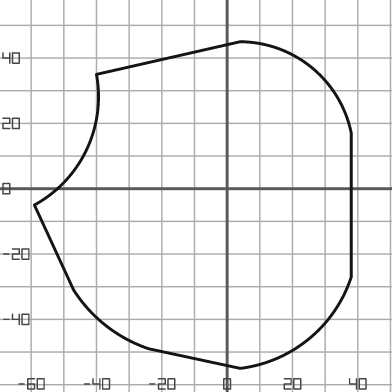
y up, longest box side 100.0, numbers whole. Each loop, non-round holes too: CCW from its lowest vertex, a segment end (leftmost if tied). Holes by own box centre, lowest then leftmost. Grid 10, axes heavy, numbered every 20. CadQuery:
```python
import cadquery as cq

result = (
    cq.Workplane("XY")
    .moveTo(4.0, -55.0)
    .threePointArc((25.0, -46.0), (38.0, -27.0))
    .lineTo(38.0, 17.0)
    .threePointArc((26.0, 37.0), (4.0, 45.0))
    .lineTo(-40.0, 35.0)
    .threePointArc((-43.0, 12.0), (-59.0, -5.0))
    .lineTo(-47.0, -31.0)
    .threePointArc((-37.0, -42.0), (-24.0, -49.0))
    .close()
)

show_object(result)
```